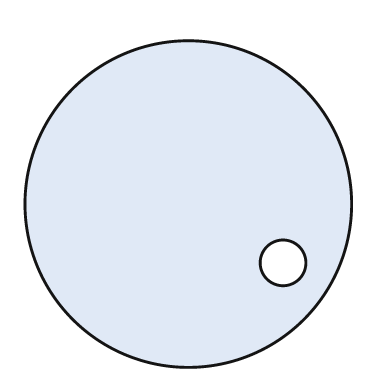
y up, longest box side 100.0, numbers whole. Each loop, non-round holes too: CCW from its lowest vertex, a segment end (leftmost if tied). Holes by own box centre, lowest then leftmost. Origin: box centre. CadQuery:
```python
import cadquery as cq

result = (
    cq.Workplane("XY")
    .moveTo(0.0, 0.0)
    .circle(50.0)
    .moveTo(29.0, -18.0)
    .circle(7.0)
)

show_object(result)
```